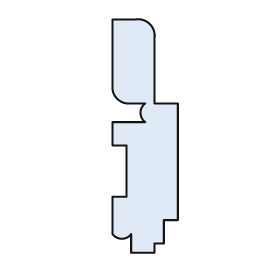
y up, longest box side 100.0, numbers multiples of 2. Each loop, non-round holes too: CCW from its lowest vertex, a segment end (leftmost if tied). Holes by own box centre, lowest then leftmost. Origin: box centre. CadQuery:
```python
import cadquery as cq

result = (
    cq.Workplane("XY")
    .moveTo(-6.0, -50.0)
    .lineTo(4.0, -50.0)
    .lineTo(4.0, -46.0)
    .lineTo(8.0, -46.0)
    .lineTo(8.0, -36.0)
    .lineTo(14.0, -36.0)
    .lineTo(14.0, 14.0)
    .lineTo(4.0, 14.0)
    .lineTo(4.0, 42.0)
    .threePointArc((2.0, 48.0), (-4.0, 50.0))
    .lineTo(-14.0, 50.0)
    .lineTo(-14.0, 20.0)
    .threePointArc((-12.0, 16.0), (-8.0, 14.0))
    .lineTo(0.0, 14.0)
    .threePointArc((-2.0, 10.0), (0.0, 6.0))
    .lineTo(-14.0, 6.0)
    .lineTo(-14.0, -4.0)
    .lineTo(-8.0, -4.0)
    .lineTo(-8.0, -26.0)
    .lineTo(-14.0, -26.0)
    .lineTo(-14.0, -42.0)
    .threePointArc((-10.0, -44.0), (-6.0, -42.0))
    .close()
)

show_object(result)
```